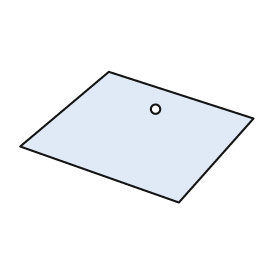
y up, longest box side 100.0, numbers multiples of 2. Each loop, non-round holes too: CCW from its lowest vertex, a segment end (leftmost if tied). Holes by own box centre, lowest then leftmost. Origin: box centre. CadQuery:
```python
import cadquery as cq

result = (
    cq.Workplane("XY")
    .moveTo(18.0, -28.0)
    .lineTo(50.0, 8.0)
    .lineTo(-12.0, 28.0)
    .lineTo(-50.0, -4.0)
    .close()
    .moveTo(8.0, 12.0)
    .circle(2.0)
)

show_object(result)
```